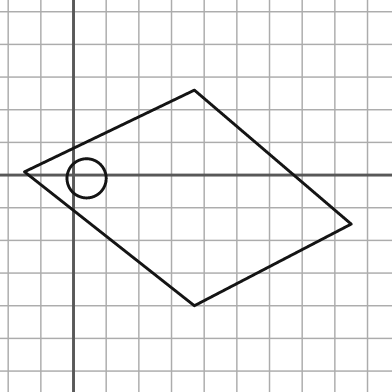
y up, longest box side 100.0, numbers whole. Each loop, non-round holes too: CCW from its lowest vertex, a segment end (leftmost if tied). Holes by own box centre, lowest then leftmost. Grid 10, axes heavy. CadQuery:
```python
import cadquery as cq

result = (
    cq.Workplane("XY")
    .moveTo(37.0, -40.0)
    .lineTo(85.0, -15.0)
    .lineTo(37.0, 26.0)
    .lineTo(-15.0, 1.0)
    .close()
    .moveTo(4.0, -1.0)
    .circle(6.0)
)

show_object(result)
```